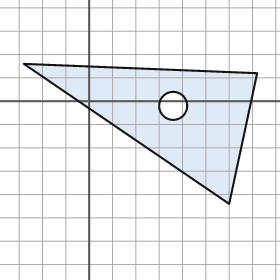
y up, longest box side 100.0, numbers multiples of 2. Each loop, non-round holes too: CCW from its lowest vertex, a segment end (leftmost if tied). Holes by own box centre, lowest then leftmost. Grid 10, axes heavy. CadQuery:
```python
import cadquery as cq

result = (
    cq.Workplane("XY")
    .moveTo(60.0, -44.0)
    .lineTo(72.0, 12.0)
    .lineTo(-28.0, 16.0)
    .close()
    .moveTo(36.0, -2.0)
    .circle(6.0)
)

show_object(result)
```